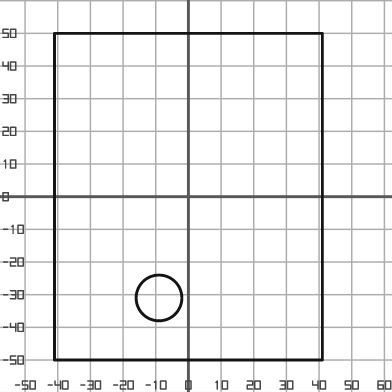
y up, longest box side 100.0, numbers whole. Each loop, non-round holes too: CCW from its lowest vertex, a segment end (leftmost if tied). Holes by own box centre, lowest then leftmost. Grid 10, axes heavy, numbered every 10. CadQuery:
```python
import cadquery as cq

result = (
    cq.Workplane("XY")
    .moveTo(-41.0, -50.0)
    .lineTo(41.0, -50.0)
    .lineTo(41.0, 50.0)
    .lineTo(-41.0, 50.0)
    .close()
    .moveTo(-9.0, -31.0)
    .circle(7.0)
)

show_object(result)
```